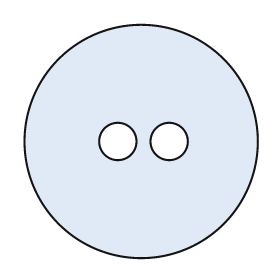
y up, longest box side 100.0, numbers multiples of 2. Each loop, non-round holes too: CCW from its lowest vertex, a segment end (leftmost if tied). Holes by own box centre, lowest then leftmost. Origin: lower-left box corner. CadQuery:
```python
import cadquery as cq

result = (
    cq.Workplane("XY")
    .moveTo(50.0, 50.0)
    .circle(50.0)
    .moveTo(40.0, 50.0)
    .circle(8.0)
    .moveTo(62.0, 50.0)
    .circle(8.0)
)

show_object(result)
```